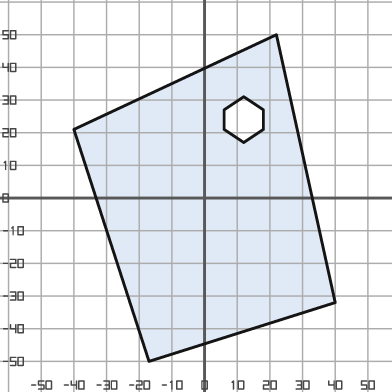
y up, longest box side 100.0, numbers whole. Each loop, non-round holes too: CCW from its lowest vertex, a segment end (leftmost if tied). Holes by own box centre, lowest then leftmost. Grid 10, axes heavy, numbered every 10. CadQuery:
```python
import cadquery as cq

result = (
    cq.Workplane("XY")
    .moveTo(-17.0, -50.0)
    .lineTo(40.0, -32.0)
    .lineTo(22.0, 50.0)
    .lineTo(-40.0, 21.0)
    .close()
    .moveTo(12.0, 17.0)
    .lineTo(18.0, 21.0)
    .lineTo(18.0, 27.0)
    .lineTo(12.0, 31.0)
    .lineTo(6.0, 27.0)
    .lineTo(6.0, 21.0)
    .close()
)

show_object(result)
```